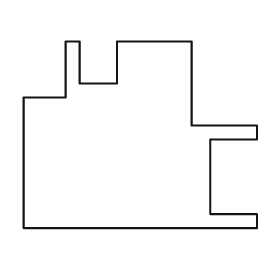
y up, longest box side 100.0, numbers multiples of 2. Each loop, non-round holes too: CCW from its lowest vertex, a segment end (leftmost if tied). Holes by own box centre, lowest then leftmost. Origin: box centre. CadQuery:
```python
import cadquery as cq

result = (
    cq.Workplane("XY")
    .moveTo(-50.0, -40.0)
    .lineTo(50.0, -40.0)
    .lineTo(50.0, -34.0)
    .lineTo(30.0, -34.0)
    .lineTo(30.0, -2.0)
    .lineTo(50.0, -2.0)
    .lineTo(50.0, 4.0)
    .lineTo(22.0, 4.0)
    .lineTo(22.0, 40.0)
    .lineTo(-10.0, 40.0)
    .lineTo(-10.0, 22.0)
    .lineTo(-26.0, 22.0)
    .lineTo(-26.0, 40.0)
    .lineTo(-32.0, 40.0)
    .lineTo(-32.0, 16.0)
    .lineTo(-50.0, 16.0)
    .close()
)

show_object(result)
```